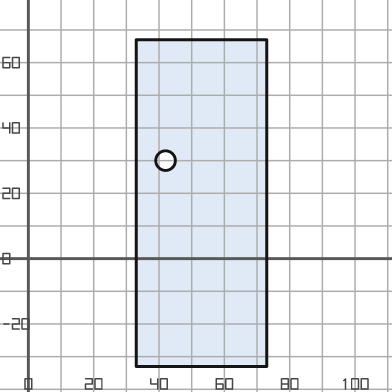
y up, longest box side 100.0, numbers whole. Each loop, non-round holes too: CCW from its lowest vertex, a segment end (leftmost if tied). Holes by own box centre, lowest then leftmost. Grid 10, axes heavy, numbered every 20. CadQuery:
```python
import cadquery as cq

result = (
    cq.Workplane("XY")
    .moveTo(33.0, -33.0)
    .lineTo(73.0, -33.0)
    .lineTo(73.0, 67.0)
    .lineTo(33.0, 67.0)
    .close()
    .moveTo(42.0, 30.0)
    .circle(3.0)
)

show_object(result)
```